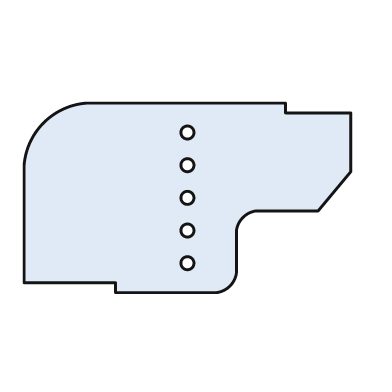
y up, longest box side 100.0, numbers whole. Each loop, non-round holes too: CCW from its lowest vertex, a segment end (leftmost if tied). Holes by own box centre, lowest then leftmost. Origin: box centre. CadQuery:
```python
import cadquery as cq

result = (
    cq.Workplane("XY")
    .moveTo(-22.0, -29.0)
    .lineTo(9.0, -29.0)
    .threePointArc((13.0, -27.0), (15.0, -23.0))
    .lineTo(15.0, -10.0)
    .threePointArc((17.0, -6.0), (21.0, -4.0))
    .lineTo(40.0, -4.0)
    .lineTo(50.0, 8.0)
    .lineTo(50.0, 26.0)
    .lineTo(30.0, 26.0)
    .lineTo(30.0, 29.0)
    .lineTo(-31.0, 29.0)
    .threePointArc((-44.0, 23.0), (-50.0, 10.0))
    .lineTo(-50.0, -26.0)
    .lineTo(-22.0, -26.0)
    .close()
    .moveTo(0.0, -20.0)
    .circle(2.0)
    .moveTo(0.0, -10.0)
    .circle(2.0)
    .moveTo(0.0, 0.0)
    .circle(2.0)
    .moveTo(0.0, 10.0)
    .circle(2.0)
    .moveTo(0.0, 20.0)
    .circle(2.0)
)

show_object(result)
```